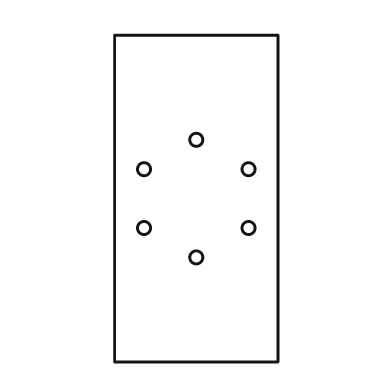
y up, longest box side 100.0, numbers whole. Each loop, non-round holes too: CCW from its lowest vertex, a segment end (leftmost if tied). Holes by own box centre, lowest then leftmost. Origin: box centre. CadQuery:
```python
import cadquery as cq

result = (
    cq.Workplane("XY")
    .moveTo(-25.0, -50.0)
    .lineTo(25.0, -50.0)
    .lineTo(25.0, 50.0)
    .lineTo(-25.0, 50.0)
    .close()
    .moveTo(0.0, -18.0)
    .circle(2.0)
    .moveTo(-16.0, -9.0)
    .circle(2.0)
    .moveTo(16.0, -9.0)
    .circle(2.0)
    .moveTo(-16.0, 9.0)
    .circle(2.0)
    .moveTo(16.0, 9.0)
    .circle(2.0)
    .moveTo(0.0, 18.0)
    .circle(2.0)
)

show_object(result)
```